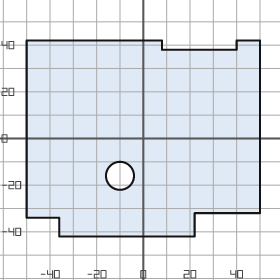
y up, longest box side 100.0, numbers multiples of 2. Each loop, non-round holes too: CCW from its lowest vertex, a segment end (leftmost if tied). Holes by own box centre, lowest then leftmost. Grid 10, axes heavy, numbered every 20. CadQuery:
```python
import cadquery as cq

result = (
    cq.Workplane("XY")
    .moveTo(-36.0, -42.0)
    .lineTo(22.0, -42.0)
    .lineTo(22.0, -32.0)
    .lineTo(50.0, -32.0)
    .lineTo(50.0, 42.0)
    .lineTo(40.0, 42.0)
    .lineTo(40.0, 38.0)
    .lineTo(8.0, 38.0)
    .lineTo(8.0, 42.0)
    .lineTo(-50.0, 42.0)
    .lineTo(-50.0, -34.0)
    .lineTo(-36.0, -34.0)
    .close()
    .moveTo(-10.0, -16.0)
    .circle(6.0)
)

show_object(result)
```